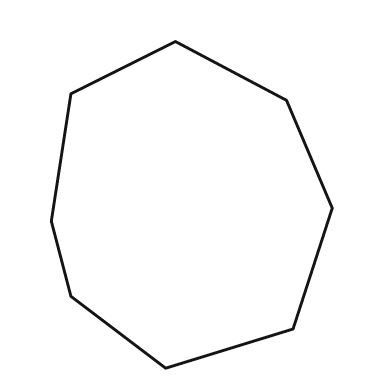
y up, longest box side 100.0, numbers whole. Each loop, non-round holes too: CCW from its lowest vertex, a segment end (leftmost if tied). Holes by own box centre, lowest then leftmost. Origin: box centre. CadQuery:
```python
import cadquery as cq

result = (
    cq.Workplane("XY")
    .moveTo(-8.0, -50.0)
    .lineTo(31.0, -38.0)
    .lineTo(43.0, -1.0)
    .lineTo(29.0, 32.0)
    .lineTo(-5.0, 50.0)
    .lineTo(-37.0, 34.0)
    .lineTo(-43.0, -5.0)
    .lineTo(-37.0, -28.0)
    .close()
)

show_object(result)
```